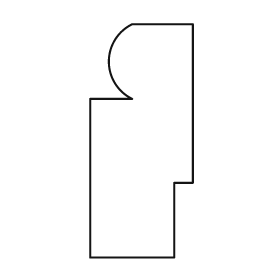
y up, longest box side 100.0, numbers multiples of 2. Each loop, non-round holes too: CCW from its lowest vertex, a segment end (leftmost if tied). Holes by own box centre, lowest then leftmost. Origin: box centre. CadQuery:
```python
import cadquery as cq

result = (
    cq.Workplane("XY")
    .moveTo(-22.0, -50.0)
    .lineTo(14.0, -50.0)
    .lineTo(14.0, -18.0)
    .lineTo(22.0, -18.0)
    .lineTo(22.0, 50.0)
    .lineTo(-4.0, 50.0)
    .threePointArc((-14.0, 34.0), (-4.0, 18.0))
    .lineTo(-22.0, 18.0)
    .close()
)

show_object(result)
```